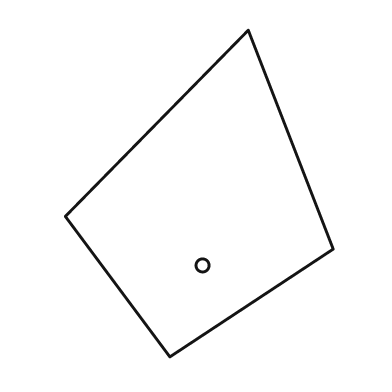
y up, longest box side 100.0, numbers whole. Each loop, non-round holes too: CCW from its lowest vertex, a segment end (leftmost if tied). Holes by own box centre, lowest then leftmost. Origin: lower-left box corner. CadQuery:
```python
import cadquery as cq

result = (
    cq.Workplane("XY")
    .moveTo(32.0, 0.0)
    .lineTo(82.0, 33.0)
    .lineTo(56.0, 100.0)
    .lineTo(0.0, 43.0)
    .close()
    .moveTo(42.0, 28.0)
    .circle(2.0)
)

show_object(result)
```